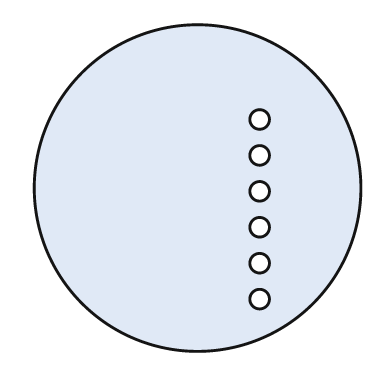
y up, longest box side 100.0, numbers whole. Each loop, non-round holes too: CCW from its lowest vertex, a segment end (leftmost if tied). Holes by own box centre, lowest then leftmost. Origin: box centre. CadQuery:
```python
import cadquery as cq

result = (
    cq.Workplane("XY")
    .moveTo(0.0, 0.0)
    .circle(50.0)
    .moveTo(19.0, -34.0)
    .circle(3.0)
    .moveTo(19.0, -23.0)
    .circle(3.0)
    .moveTo(19.0, -12.0)
    .circle(3.0)
    .moveTo(19.0, -1.0)
    .circle(3.0)
    .moveTo(19.0, 10.0)
    .circle(3.0)
    .moveTo(19.0, 21.0)
    .circle(3.0)
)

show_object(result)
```